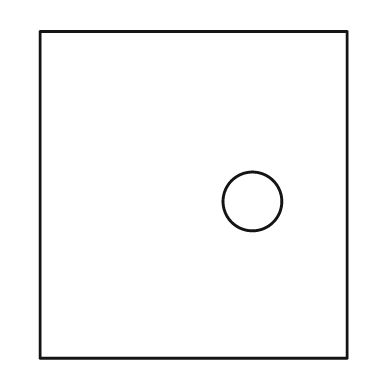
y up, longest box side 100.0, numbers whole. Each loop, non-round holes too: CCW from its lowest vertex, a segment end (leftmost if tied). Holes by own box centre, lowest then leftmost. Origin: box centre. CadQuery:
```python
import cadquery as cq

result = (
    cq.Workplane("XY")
    .moveTo(-47.0, -50.0)
    .lineTo(47.0, -50.0)
    .lineTo(47.0, 50.0)
    .lineTo(-47.0, 50.0)
    .close()
    .moveTo(18.0, -2.0)
    .circle(9.0)
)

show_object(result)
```